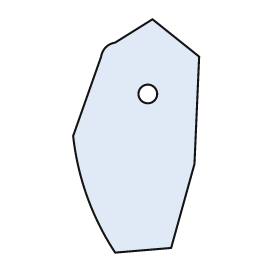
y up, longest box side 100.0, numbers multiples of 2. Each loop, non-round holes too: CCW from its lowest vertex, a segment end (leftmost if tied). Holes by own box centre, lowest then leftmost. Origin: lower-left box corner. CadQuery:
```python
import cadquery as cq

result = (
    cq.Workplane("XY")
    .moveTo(18.0, 0.0)
    .lineTo(42.0, 2.0)
    .lineTo(52.0, 38.0)
    .lineTo(54.0, 84.0)
    .lineTo(34.0, 100.0)
    .lineTo(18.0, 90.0)
    .threePointArc((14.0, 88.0), (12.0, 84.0))
    .lineTo(0.0, 50.0)
    .threePointArc((6.0, 24.0), (18.0, 0.0))
    .close()
    .moveTo(32.0, 68.0)
    .circle(4.0)
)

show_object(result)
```